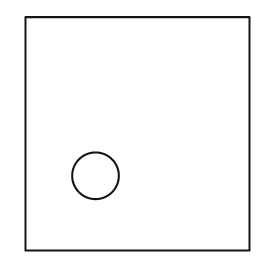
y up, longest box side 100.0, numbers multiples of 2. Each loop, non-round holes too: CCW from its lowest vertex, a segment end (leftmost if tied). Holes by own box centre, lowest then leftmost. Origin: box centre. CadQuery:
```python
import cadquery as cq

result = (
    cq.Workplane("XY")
    .moveTo(-48.0, -50.0)
    .lineTo(48.0, -50.0)
    .lineTo(48.0, 50.0)
    .lineTo(-48.0, 50.0)
    .close()
    .moveTo(-18.0, -18.0)
    .circle(10.0)
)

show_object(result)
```